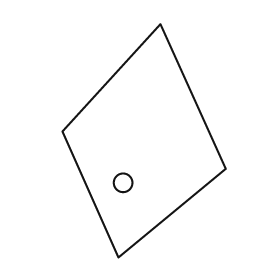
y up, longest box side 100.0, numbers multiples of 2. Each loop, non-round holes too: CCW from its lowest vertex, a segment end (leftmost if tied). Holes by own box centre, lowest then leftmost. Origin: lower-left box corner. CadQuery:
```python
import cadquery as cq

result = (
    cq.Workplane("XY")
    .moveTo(24.0, 0.0)
    .lineTo(70.0, 38.0)
    .lineTo(42.0, 100.0)
    .lineTo(0.0, 54.0)
    .close()
    .moveTo(26.0, 32.0)
    .circle(4.0)
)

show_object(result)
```